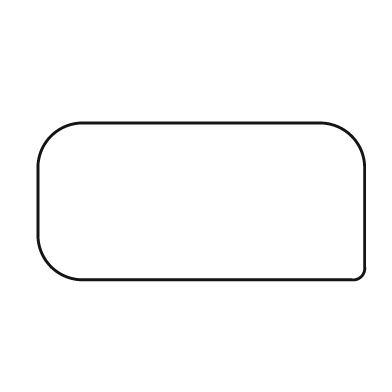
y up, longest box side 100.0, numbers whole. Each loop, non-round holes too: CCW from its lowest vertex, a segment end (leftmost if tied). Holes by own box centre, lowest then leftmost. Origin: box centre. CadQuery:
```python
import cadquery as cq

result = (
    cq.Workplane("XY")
    .moveTo(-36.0, -24.0)
    .lineTo(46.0, -24.0)
    .threePointArc((49.0, -23.0), (50.0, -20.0))
    .lineTo(50.0, 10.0)
    .threePointArc((46.0, 20.0), (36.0, 24.0))
    .lineTo(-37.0, 24.0)
    .threePointArc((-46.0, 20.0), (-50.0, 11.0))
    .lineTo(-50.0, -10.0)
    .threePointArc((-46.0, -20.0), (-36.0, -24.0))
    .close()
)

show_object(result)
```